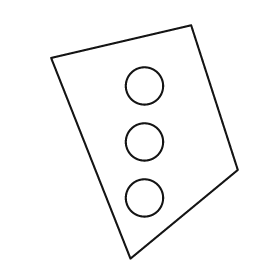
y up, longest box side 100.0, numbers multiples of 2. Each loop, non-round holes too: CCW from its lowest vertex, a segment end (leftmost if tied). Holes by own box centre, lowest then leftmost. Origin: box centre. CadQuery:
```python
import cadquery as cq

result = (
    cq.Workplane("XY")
    .moveTo(-6.0, -50.0)
    .lineTo(40.0, -12.0)
    .lineTo(20.0, 50.0)
    .lineTo(-40.0, 36.0)
    .close()
    .moveTo(0.0, -24.0)
    .circle(8.0)
    .moveTo(0.0, 0.0)
    .circle(8.0)
    .moveTo(0.0, 24.0)
    .circle(8.0)
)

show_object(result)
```